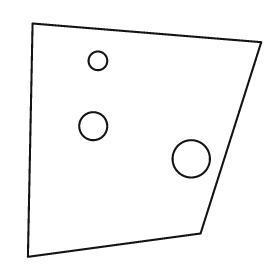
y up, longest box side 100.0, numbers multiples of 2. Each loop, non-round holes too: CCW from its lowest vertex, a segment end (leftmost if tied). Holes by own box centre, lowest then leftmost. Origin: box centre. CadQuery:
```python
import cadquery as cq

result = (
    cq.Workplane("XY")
    .moveTo(-50.0, -50.0)
    .lineTo(24.0, -40.0)
    .lineTo(50.0, 42.0)
    .lineTo(-48.0, 50.0)
    .close()
    .moveTo(20.0, -8.0)
    .circle(8.0)
    .moveTo(-22.0, 6.0)
    .circle(6.0)
    .moveTo(-20.0, 34.0)
    .circle(4.0)
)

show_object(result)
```